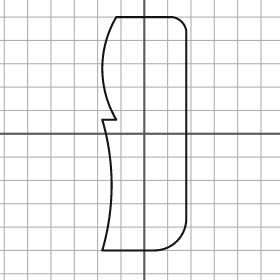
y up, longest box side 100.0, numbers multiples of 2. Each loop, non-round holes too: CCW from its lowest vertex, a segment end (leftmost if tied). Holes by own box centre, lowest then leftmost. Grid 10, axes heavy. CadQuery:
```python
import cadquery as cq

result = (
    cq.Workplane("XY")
    .moveTo(-18.0, -50.0)
    .lineTo(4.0, -50.0)
    .threePointArc((14.0, -46.0), (18.0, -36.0))
    .lineTo(18.0, 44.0)
    .threePointArc((16.0, 48.0), (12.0, 50.0))
    .lineTo(-12.0, 50.0)
    .threePointArc((-18.0, 28.0), (-12.0, 6.0))
    .lineTo(-18.0, 6.0)
    .threePointArc((-14.0, -22.0), (-18.0, -50.0))
    .close()
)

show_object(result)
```